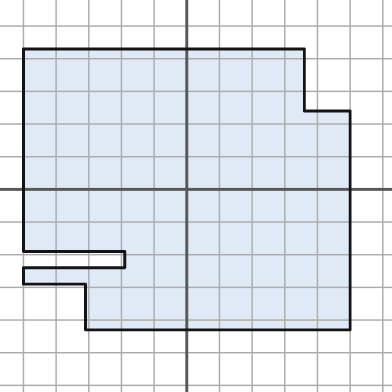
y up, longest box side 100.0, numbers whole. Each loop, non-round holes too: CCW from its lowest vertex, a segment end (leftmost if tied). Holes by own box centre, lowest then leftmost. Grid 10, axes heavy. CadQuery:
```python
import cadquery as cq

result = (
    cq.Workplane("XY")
    .moveTo(-31.0, -43.0)
    .lineTo(50.0, -43.0)
    .lineTo(50.0, 24.0)
    .lineTo(36.0, 24.0)
    .lineTo(36.0, 43.0)
    .lineTo(-50.0, 43.0)
    .lineTo(-50.0, -19.0)
    .lineTo(-19.0, -19.0)
    .lineTo(-19.0, -24.0)
    .lineTo(-50.0, -24.0)
    .lineTo(-50.0, -29.0)
    .lineTo(-31.0, -29.0)
    .close()
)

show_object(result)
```